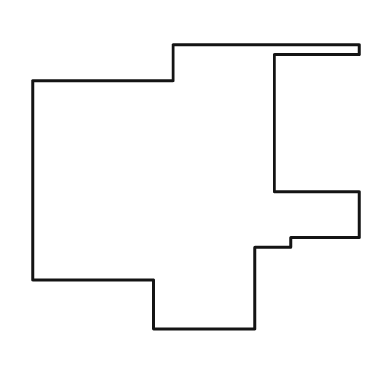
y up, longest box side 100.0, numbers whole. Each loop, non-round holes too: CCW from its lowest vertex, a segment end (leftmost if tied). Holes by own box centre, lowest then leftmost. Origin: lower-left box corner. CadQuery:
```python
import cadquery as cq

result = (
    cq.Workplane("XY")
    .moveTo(37.0, 0.0)
    .lineTo(68.0, 0.0)
    .lineTo(68.0, 25.0)
    .lineTo(79.0, 25.0)
    .lineTo(79.0, 28.0)
    .lineTo(100.0, 28.0)
    .lineTo(100.0, 42.0)
    .lineTo(74.0, 42.0)
    .lineTo(74.0, 84.0)
    .lineTo(100.0, 84.0)
    .lineTo(100.0, 87.0)
    .lineTo(43.0, 87.0)
    .lineTo(43.0, 76.0)
    .lineTo(0.0, 76.0)
    .lineTo(0.0, 15.0)
    .lineTo(37.0, 15.0)
    .close()
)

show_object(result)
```